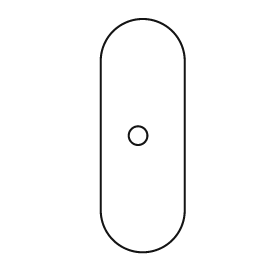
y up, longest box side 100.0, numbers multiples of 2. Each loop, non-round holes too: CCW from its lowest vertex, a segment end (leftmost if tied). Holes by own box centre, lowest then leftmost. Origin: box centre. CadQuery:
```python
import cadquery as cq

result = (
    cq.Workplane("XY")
    .moveTo(-18.0, -32.0)
    .threePointArc((0.0, -50.0), (18.0, -32.0))
    .lineTo(18.0, 32.0)
    .threePointArc((0.0, 50.0), (-18.0, 32.0))
    .close()
    .moveTo(-2.0, 0.0)
    .circle(4.0)
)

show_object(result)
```